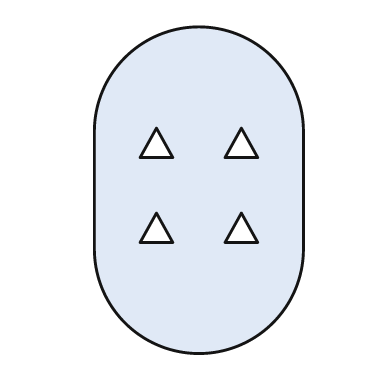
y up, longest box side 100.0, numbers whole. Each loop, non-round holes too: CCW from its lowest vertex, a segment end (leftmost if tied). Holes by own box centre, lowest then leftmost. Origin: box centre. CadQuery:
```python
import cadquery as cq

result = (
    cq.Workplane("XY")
    .moveTo(-32.0, -18.0)
    .threePointArc((0.0, -50.0), (32.0, -18.0))
    .lineTo(32.0, 18.0)
    .threePointArc((0.0, 50.0), (-32.0, 18.0))
    .close()
    .moveTo(-18.0, -16.0)
    .lineTo(-8.0, -16.0)
    .lineTo(-13.0, -7.0)
    .close()
    .moveTo(8.0, -16.0)
    .lineTo(18.0, -16.0)
    .lineTo(13.0, -7.0)
    .close()
    .moveTo(-18.0, 10.0)
    .lineTo(-8.0, 10.0)
    .lineTo(-13.0, 19.0)
    .close()
    .moveTo(8.0, 10.0)
    .lineTo(18.0, 10.0)
    .lineTo(13.0, 19.0)
    .close()
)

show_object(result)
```